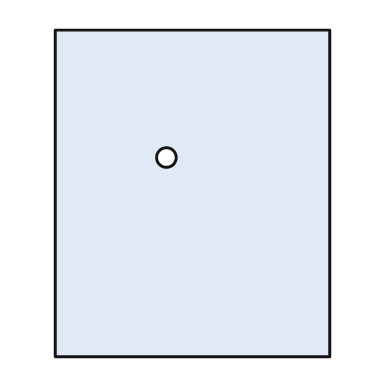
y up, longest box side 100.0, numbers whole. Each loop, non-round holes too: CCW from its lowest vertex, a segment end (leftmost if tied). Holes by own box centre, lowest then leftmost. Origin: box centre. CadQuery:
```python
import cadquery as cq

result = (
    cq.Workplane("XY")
    .moveTo(-42.0, -50.0)
    .lineTo(42.0, -50.0)
    .lineTo(42.0, 50.0)
    .lineTo(-42.0, 50.0)
    .close()
    .moveTo(-8.0, 11.0)
    .circle(3.0)
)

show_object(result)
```